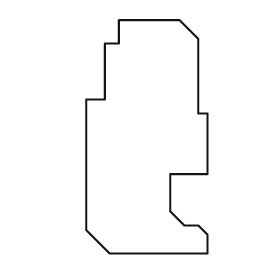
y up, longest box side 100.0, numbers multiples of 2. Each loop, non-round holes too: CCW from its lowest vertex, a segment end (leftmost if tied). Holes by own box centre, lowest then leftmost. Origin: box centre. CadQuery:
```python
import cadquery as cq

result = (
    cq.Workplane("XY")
    .moveTo(-16.0, -50.0)
    .lineTo(26.0, -50.0)
    .lineTo(26.0, -42.0)
    .lineTo(22.0, -38.0)
    .lineTo(16.0, -38.0)
    .lineTo(10.0, -32.0)
    .lineTo(10.0, -16.0)
    .lineTo(26.0, -16.0)
    .lineTo(26.0, 10.0)
    .lineTo(22.0, 10.0)
    .lineTo(22.0, 42.0)
    .lineTo(14.0, 50.0)
    .lineTo(-12.0, 50.0)
    .lineTo(-12.0, 40.0)
    .lineTo(-18.0, 40.0)
    .lineTo(-18.0, 16.0)
    .lineTo(-26.0, 16.0)
    .lineTo(-26.0, -40.0)
    .close()
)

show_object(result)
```